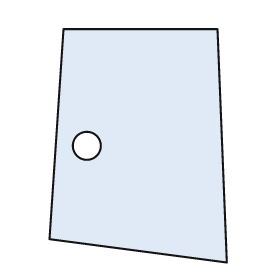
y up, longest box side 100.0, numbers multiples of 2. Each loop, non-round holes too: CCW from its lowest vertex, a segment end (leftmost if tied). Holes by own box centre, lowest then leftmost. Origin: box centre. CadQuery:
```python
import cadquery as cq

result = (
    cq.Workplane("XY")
    .moveTo(38.0, -50.0)
    .lineTo(34.0, 50.0)
    .lineTo(-32.0, 50.0)
    .lineTo(-38.0, -40.0)
    .close()
    .moveTo(-22.0, 0.0)
    .circle(6.0)
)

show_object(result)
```